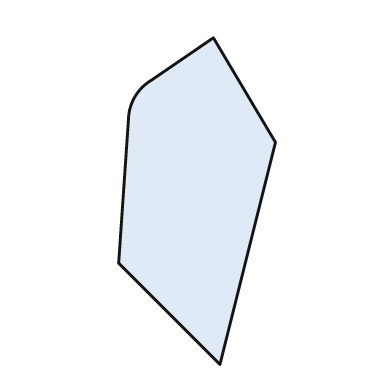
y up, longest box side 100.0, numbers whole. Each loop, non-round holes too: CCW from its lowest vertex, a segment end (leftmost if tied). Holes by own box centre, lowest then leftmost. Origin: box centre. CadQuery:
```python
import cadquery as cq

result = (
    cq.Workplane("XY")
    .moveTo(7.0, -50.0)
    .lineTo(24.0, 18.0)
    .lineTo(5.0, 50.0)
    .lineTo(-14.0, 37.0)
    .threePointArc((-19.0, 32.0), (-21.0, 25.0))
    .lineTo(-24.0, -19.0)
    .close()
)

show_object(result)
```